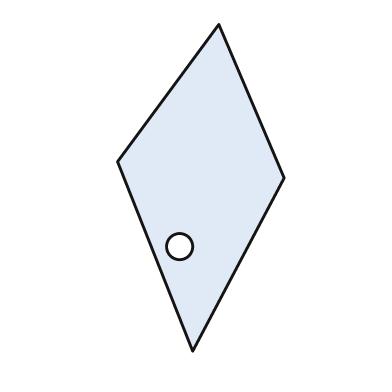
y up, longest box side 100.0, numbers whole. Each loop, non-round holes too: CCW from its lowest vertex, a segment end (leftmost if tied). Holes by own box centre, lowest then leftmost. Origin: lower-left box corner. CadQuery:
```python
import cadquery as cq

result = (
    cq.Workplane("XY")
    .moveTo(23.0, 0.0)
    .lineTo(51.0, 53.0)
    .lineTo(31.0, 100.0)
    .lineTo(0.0, 58.0)
    .close()
    .moveTo(19.0, 32.0)
    .circle(4.0)
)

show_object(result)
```